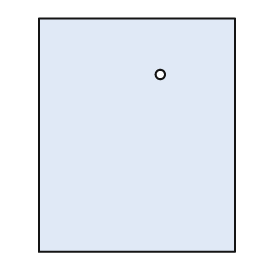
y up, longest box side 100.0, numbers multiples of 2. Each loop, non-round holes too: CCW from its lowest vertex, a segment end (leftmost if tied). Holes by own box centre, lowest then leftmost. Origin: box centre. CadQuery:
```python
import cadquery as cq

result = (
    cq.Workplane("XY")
    .moveTo(-42.0, -50.0)
    .lineTo(42.0, -50.0)
    .lineTo(42.0, 50.0)
    .lineTo(-42.0, 50.0)
    .close()
    .moveTo(10.0, 26.0)
    .circle(2.0)
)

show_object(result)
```